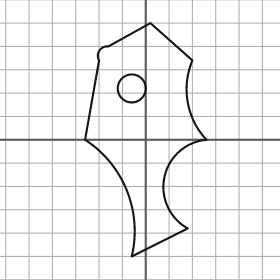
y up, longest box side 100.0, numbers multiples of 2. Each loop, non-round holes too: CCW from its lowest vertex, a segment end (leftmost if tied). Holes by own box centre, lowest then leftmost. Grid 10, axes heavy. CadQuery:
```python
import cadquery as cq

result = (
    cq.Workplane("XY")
    .moveTo(-6.0, -50.0)
    .lineTo(18.0, -38.0)
    .threePointArc((8.0, -16.0), (26.0, 0.0))
    .threePointArc((18.0, 16.0), (20.0, 34.0))
    .lineTo(2.0, 50.0)
    .lineTo(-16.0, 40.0)
    .threePointArc((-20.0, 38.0), (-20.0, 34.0))
    .lineTo(-26.0, 0.0)
    .threePointArc((-8.0, -22.0), (-6.0, -50.0))
    .close()
    .moveTo(-6.0, 22.0)
    .circle(6.0)
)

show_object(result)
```